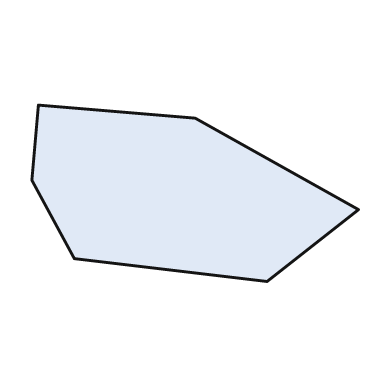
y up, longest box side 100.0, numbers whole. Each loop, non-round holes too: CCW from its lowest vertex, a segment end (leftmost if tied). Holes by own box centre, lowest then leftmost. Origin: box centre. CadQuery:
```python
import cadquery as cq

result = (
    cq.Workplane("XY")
    .moveTo(22.0, -27.0)
    .lineTo(50.0, -5.0)
    .lineTo(0.0, 23.0)
    .lineTo(-48.0, 27.0)
    .lineTo(-50.0, 4.0)
    .lineTo(-37.0, -20.0)
    .close()
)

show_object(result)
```